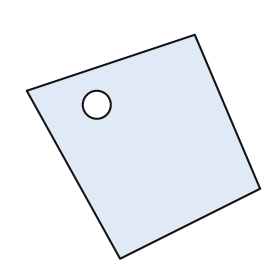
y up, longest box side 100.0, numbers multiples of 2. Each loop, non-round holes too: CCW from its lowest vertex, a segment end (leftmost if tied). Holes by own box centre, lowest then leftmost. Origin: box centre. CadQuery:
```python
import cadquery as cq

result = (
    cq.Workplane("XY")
    .moveTo(-10.0, -48.0)
    .lineTo(50.0, -18.0)
    .lineTo(22.0, 48.0)
    .lineTo(-50.0, 24.0)
    .close()
    .moveTo(-20.0, 18.0)
    .circle(6.0)
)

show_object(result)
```